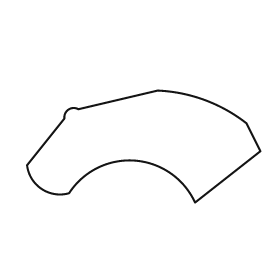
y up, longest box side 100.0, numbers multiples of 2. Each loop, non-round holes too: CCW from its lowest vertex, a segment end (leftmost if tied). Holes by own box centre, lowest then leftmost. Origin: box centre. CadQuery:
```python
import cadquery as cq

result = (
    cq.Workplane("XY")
    .moveTo(22.0, -24.0)
    .lineTo(50.0, -2.0)
    .lineTo(44.0, 10.0)
    .threePointArc((26.0, 20.0), (6.0, 24.0))
    .lineTo(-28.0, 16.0)
    .threePointArc((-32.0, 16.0), (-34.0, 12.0))
    .lineTo(-50.0, -8.0)
    .threePointArc((-44.0, -18.0), (-32.0, -20.0))
    .threePointArc((-4.0, -6.0), (22.0, -24.0))
    .close()
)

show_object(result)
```